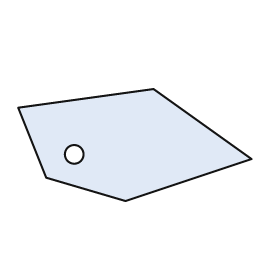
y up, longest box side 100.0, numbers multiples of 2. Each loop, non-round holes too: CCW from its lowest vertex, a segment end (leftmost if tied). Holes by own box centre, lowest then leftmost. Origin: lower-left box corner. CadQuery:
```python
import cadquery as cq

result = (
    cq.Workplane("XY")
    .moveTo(46.0, 0.0)
    .lineTo(100.0, 18.0)
    .lineTo(58.0, 48.0)
    .lineTo(0.0, 40.0)
    .lineTo(12.0, 10.0)
    .close()
    .moveTo(24.0, 20.0)
    .circle(4.0)
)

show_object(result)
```